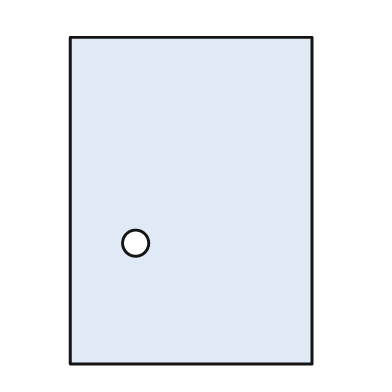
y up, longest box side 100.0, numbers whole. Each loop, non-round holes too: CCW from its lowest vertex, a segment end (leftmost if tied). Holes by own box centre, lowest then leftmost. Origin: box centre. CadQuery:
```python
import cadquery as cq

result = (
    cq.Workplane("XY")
    .moveTo(-37.0, -50.0)
    .lineTo(37.0, -50.0)
    .lineTo(37.0, 50.0)
    .lineTo(-37.0, 50.0)
    .close()
    .moveTo(-17.0, -13.0)
    .circle(4.0)
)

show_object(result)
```